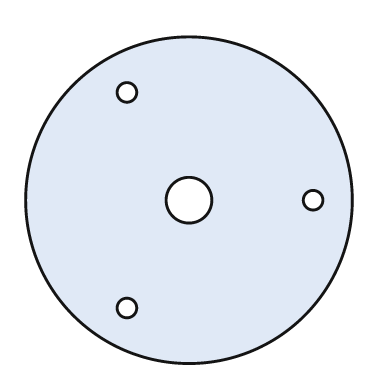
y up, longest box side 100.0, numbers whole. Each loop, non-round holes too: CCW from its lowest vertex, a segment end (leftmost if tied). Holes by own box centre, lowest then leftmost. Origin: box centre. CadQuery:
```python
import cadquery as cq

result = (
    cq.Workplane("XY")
    .moveTo(0.0, 0.0)
    .circle(50.0)
    .moveTo(-19.0, -33.0)
    .circle(3.0)
    .moveTo(0.0, 0.0)
    .circle(7.0)
    .moveTo(38.0, 0.0)
    .circle(3.0)
    .moveTo(-19.0, 33.0)
    .circle(3.0)
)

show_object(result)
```